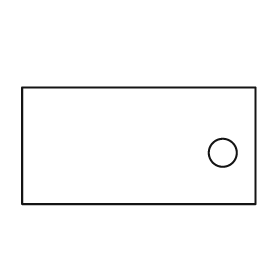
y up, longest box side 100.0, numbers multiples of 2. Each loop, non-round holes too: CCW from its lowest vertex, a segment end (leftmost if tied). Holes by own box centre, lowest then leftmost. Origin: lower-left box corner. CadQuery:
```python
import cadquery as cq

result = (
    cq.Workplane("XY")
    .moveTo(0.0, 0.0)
    .lineTo(100.0, 0.0)
    .lineTo(100.0, 50.0)
    .lineTo(0.0, 50.0)
    .close()
    .moveTo(86.0, 22.0)
    .circle(6.0)
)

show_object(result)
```